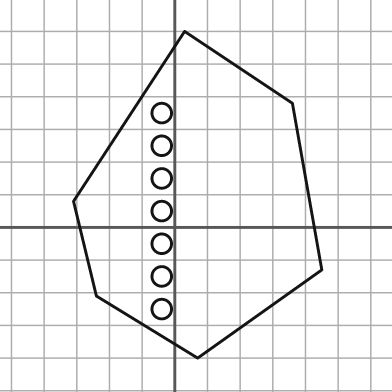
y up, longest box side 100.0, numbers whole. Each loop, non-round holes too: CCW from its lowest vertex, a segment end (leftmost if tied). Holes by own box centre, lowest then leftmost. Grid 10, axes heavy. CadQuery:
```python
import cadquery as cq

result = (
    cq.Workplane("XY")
    .moveTo(7.0, -40.0)
    .lineTo(45.0, -13.0)
    .lineTo(36.0, 38.0)
    .lineTo(3.0, 60.0)
    .lineTo(-31.0, 8.0)
    .lineTo(-24.0, -21.0)
    .close()
    .moveTo(-4.0, -25.0)
    .circle(3.0)
    .moveTo(-4.0, -15.0)
    .circle(3.0)
    .moveTo(-4.0, -5.0)
    .circle(3.0)
    .moveTo(-4.0, 5.0)
    .circle(3.0)
    .moveTo(-4.0, 15.0)
    .circle(3.0)
    .moveTo(-4.0, 25.0)
    .circle(3.0)
    .moveTo(-4.0, 35.0)
    .circle(3.0)
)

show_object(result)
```